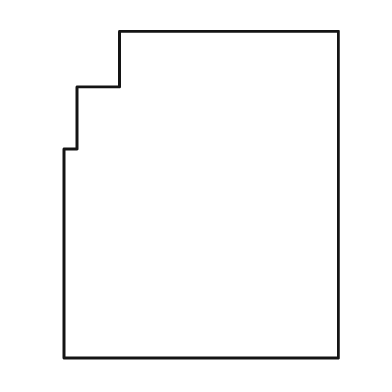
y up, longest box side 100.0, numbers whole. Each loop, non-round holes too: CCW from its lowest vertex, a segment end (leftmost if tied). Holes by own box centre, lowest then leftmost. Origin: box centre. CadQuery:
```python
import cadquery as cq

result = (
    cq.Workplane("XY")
    .moveTo(-42.0, -50.0)
    .lineTo(42.0, -50.0)
    .lineTo(42.0, 50.0)
    .lineTo(-25.0, 50.0)
    .lineTo(-25.0, 33.0)
    .lineTo(-38.0, 33.0)
    .lineTo(-38.0, 14.0)
    .lineTo(-42.0, 14.0)
    .close()
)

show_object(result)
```